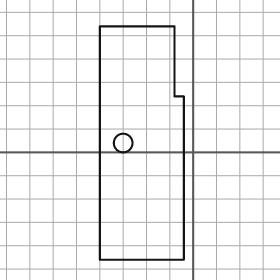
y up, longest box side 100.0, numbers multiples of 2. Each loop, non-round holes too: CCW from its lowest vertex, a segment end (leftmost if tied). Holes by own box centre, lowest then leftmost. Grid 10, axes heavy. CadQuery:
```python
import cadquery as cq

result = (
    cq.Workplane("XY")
    .moveTo(-40.0, -46.0)
    .lineTo(-4.0, -46.0)
    .lineTo(-4.0, 24.0)
    .lineTo(-8.0, 24.0)
    .lineTo(-8.0, 54.0)
    .lineTo(-40.0, 54.0)
    .close()
    .moveTo(-30.0, 4.0)
    .circle(4.0)
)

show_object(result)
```